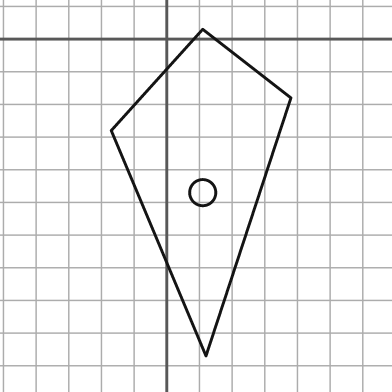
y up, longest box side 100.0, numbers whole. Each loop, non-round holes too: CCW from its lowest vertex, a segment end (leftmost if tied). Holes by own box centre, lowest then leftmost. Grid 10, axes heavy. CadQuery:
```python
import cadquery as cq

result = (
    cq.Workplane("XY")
    .moveTo(12.0, -97.0)
    .lineTo(38.0, -18.0)
    .lineTo(11.0, 3.0)
    .lineTo(-17.0, -28.0)
    .close()
    .moveTo(11.0, -47.0)
    .circle(4.0)
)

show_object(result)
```